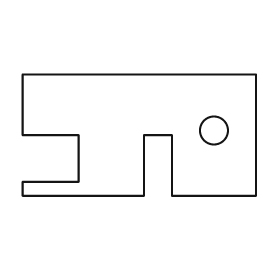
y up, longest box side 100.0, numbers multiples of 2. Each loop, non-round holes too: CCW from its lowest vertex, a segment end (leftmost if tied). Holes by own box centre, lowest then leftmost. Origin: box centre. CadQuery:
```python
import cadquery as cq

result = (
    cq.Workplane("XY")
    .moveTo(-50.0, -26.0)
    .lineTo(2.0, -26.0)
    .lineTo(2.0, 0.0)
    .lineTo(14.0, 0.0)
    .lineTo(14.0, -26.0)
    .lineTo(50.0, -26.0)
    .lineTo(50.0, 26.0)
    .lineTo(-50.0, 26.0)
    .lineTo(-50.0, 0.0)
    .lineTo(-26.0, 0.0)
    .lineTo(-26.0, -20.0)
    .lineTo(-50.0, -20.0)
    .close()
    .moveTo(32.0, 2.0)
    .circle(6.0)
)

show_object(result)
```